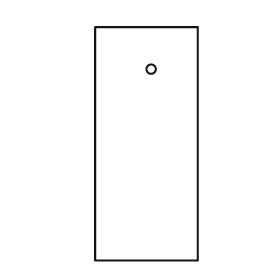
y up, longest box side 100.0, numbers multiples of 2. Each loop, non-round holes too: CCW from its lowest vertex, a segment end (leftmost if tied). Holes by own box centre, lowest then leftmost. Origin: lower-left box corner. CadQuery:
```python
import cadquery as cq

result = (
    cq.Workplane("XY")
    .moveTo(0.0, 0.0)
    .lineTo(44.0, 0.0)
    .lineTo(44.0, 100.0)
    .lineTo(0.0, 100.0)
    .close()
    .moveTo(24.0, 82.0)
    .circle(2.0)
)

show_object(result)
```